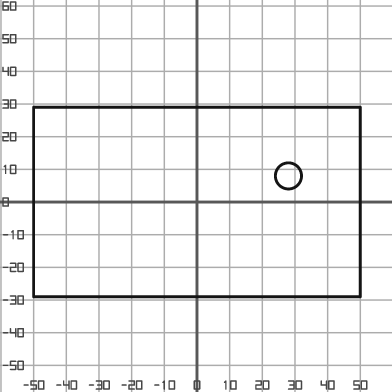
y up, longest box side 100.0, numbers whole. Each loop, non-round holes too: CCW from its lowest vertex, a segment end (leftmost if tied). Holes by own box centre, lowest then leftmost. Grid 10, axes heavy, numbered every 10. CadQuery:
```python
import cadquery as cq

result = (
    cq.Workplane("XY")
    .moveTo(-50.0, -29.0)
    .lineTo(50.0, -29.0)
    .lineTo(50.0, 29.0)
    .lineTo(-50.0, 29.0)
    .close()
    .moveTo(28.0, 8.0)
    .circle(4.0)
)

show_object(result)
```